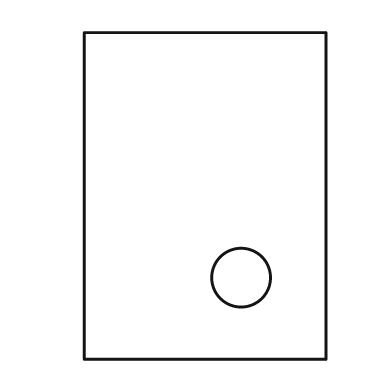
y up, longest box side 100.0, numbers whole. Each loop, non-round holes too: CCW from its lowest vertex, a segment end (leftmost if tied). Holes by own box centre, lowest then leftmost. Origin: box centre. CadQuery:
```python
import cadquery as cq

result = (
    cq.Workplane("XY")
    .moveTo(-37.0, -50.0)
    .lineTo(37.0, -50.0)
    .lineTo(37.0, 50.0)
    .lineTo(-37.0, 50.0)
    .close()
    .moveTo(11.0, -25.0)
    .circle(9.0)
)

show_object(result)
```